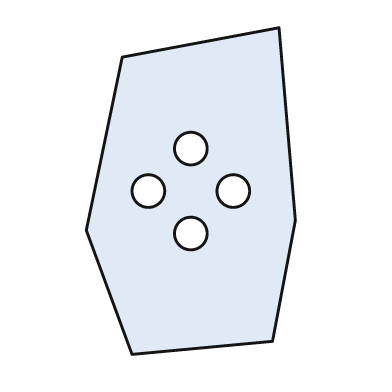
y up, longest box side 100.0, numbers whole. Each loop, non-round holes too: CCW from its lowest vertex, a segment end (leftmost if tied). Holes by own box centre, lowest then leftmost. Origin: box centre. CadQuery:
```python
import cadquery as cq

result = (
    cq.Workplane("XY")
    .moveTo(-18.0, -50.0)
    .lineTo(25.0, -46.0)
    .lineTo(32.0, -9.0)
    .lineTo(27.0, 50.0)
    .lineTo(-21.0, 41.0)
    .lineTo(-32.0, -12.0)
    .close()
    .moveTo(0.0, -13.0)
    .circle(5.0)
    .moveTo(-13.0, 0.0)
    .circle(5.0)
    .moveTo(13.0, 0.0)
    .circle(5.0)
    .moveTo(0.0, 13.0)
    .circle(5.0)
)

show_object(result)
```